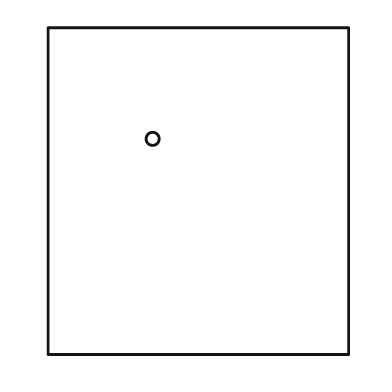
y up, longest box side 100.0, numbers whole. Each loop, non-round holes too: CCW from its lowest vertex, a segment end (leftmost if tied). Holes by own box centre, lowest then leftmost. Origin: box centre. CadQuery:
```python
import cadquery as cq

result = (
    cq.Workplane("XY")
    .moveTo(-46.0, -50.0)
    .lineTo(46.0, -50.0)
    .lineTo(46.0, 50.0)
    .lineTo(-46.0, 50.0)
    .close()
    .moveTo(-14.0, 16.0)
    .circle(2.0)
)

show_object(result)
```